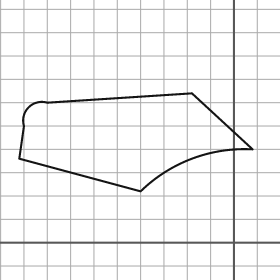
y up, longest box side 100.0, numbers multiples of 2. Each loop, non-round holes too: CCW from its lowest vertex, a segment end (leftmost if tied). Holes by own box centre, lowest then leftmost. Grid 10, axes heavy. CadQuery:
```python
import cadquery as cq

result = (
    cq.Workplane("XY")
    .moveTo(-40.0, 22.0)
    .threePointArc((-18.0, 36.0), (8.0, 40.0))
    .lineTo(-18.0, 64.0)
    .lineTo(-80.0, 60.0)
    .threePointArc((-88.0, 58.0), (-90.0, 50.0))
    .lineTo(-92.0, 36.0)
    .close()
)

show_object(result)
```